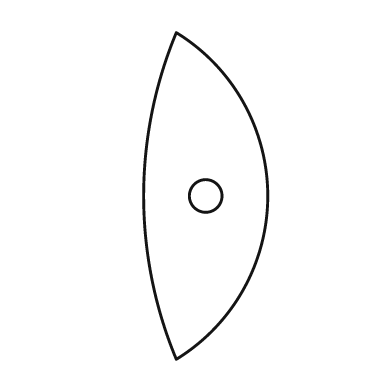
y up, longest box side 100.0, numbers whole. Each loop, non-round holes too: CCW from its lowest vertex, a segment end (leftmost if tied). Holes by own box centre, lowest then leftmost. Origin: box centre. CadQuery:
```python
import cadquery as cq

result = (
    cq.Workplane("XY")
    .moveTo(-9.0, -50.0)
    .threePointArc((19.0, 0.0), (-9.0, 50.0))
    .threePointArc((-19.0, 0.0), (-9.0, -50.0))
    .close()
    .moveTo(0.0, 0.0)
    .circle(5.0)
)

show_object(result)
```